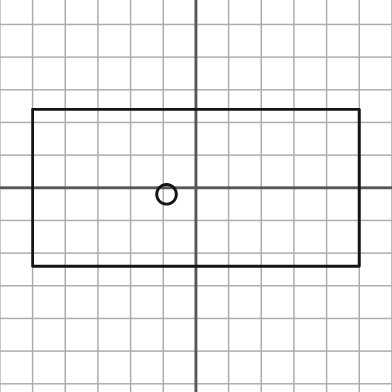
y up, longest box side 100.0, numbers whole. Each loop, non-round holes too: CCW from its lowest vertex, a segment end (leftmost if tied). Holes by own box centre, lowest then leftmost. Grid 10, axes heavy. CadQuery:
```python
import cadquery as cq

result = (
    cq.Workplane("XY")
    .moveTo(-50.0, -24.0)
    .lineTo(50.0, -24.0)
    .lineTo(50.0, 24.0)
    .lineTo(-50.0, 24.0)
    .close()
    .moveTo(-9.0, -2.0)
    .circle(3.0)
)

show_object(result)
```